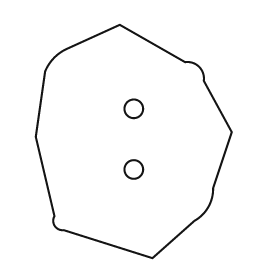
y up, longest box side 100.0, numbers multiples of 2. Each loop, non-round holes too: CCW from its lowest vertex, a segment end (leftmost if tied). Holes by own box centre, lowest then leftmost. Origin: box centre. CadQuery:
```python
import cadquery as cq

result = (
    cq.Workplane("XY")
    .moveTo(8.0, -50.0)
    .lineTo(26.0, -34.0)
    .threePointArc((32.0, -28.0), (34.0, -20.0))
    .lineTo(42.0, 4.0)
    .lineTo(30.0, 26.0)
    .threePointArc((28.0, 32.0), (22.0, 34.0))
    .lineTo(-6.0, 50.0)
    .lineTo(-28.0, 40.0)
    .threePointArc((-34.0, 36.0), (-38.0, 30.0))
    .lineTo(-42.0, 2.0)
    .lineTo(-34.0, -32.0)
    .threePointArc((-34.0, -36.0), (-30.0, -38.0))
    .close()
    .moveTo(0.0, -12.0)
    .circle(4.0)
    .moveTo(0.0, 14.0)
    .circle(4.0)
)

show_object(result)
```